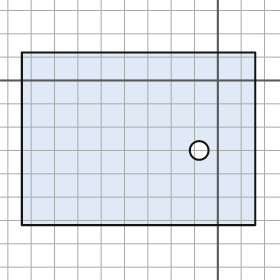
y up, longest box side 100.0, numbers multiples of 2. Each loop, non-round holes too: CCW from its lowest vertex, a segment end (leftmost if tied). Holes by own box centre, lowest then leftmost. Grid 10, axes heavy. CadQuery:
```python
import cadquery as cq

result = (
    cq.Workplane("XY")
    .moveTo(-84.0, -62.0)
    .lineTo(16.0, -62.0)
    .lineTo(16.0, 12.0)
    .lineTo(-84.0, 12.0)
    .close()
    .moveTo(-8.0, -30.0)
    .circle(4.0)
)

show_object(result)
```